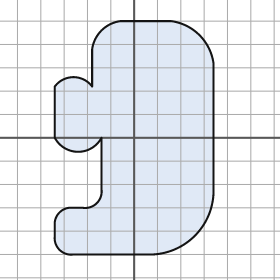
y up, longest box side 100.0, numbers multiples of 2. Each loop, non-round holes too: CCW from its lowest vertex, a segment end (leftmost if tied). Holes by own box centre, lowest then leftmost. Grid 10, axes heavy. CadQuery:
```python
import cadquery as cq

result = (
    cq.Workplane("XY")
    .moveTo(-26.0, -50.0)
    .lineTo(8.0, -50.0)
    .threePointArc((26.0, -42.0), (34.0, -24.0))
    .lineTo(34.0, 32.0)
    .threePointArc((28.0, 44.0), (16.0, 50.0))
    .lineTo(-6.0, 50.0)
    .threePointArc((-14.0, 46.0), (-18.0, 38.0))
    .lineTo(-18.0, 22.0)
    .threePointArc((-26.0, 26.0), (-34.0, 22.0))
    .lineTo(-34.0, 0.0)
    .threePointArc((-24.0, -6.0), (-14.0, 0.0))
    .lineTo(-14.0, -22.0)
    .threePointArc((-16.0, -28.0), (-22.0, -30.0))
    .lineTo(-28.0, -30.0)
    .threePointArc((-32.0, -32.0), (-34.0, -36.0))
    .lineTo(-34.0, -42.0)
    .threePointArc((-32.0, -48.0), (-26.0, -50.0))
    .close()
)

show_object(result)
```